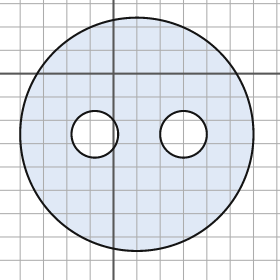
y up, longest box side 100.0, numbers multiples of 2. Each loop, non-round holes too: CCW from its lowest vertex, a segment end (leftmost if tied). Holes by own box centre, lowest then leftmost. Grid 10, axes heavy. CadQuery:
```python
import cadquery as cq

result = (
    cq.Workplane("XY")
    .moveTo(10.0, -26.0)
    .circle(50.0)
    .moveTo(-8.0, -26.0)
    .circle(10.0)
    .moveTo(30.0, -26.0)
    .circle(10.0)
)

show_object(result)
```